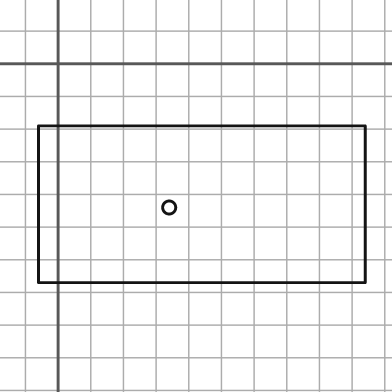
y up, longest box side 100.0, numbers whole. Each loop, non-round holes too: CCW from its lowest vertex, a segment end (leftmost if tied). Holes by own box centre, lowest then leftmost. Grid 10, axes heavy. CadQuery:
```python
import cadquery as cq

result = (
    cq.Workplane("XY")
    .moveTo(-6.0, -67.0)
    .lineTo(94.0, -67.0)
    .lineTo(94.0, -19.0)
    .lineTo(-6.0, -19.0)
    .close()
    .moveTo(34.0, -44.0)
    .circle(2.0)
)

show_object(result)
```